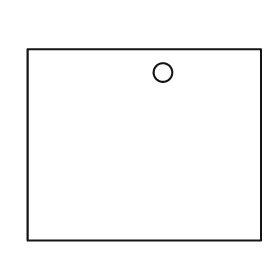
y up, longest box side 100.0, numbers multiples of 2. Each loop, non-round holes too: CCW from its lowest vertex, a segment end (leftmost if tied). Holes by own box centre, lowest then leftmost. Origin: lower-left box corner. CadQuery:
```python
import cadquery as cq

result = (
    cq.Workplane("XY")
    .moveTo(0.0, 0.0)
    .lineTo(100.0, 0.0)
    .lineTo(100.0, 82.0)
    .lineTo(0.0, 82.0)
    .close()
    .moveTo(58.0, 72.0)
    .circle(4.0)
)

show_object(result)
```